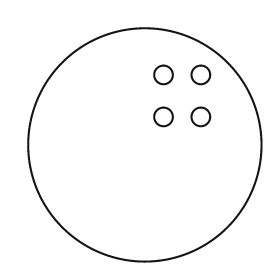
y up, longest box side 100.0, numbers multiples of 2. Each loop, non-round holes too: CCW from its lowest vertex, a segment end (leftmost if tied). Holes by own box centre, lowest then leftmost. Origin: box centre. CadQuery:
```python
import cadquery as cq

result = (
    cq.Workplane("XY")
    .moveTo(0.0, 0.0)
    .circle(50.0)
    .moveTo(8.0, 12.0)
    .circle(4.0)
    .moveTo(24.0, 12.0)
    .circle(4.0)
    .moveTo(8.0, 30.0)
    .circle(4.0)
    .moveTo(24.0, 30.0)
    .circle(4.0)
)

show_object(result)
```